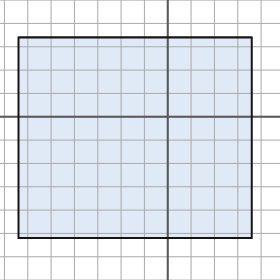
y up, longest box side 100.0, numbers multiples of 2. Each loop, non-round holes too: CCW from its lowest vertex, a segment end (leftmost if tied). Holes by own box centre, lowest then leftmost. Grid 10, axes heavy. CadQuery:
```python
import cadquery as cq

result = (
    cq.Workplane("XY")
    .moveTo(-64.0, -52.0)
    .lineTo(36.0, -52.0)
    .lineTo(36.0, 34.0)
    .lineTo(-64.0, 34.0)
    .close()
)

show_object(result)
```